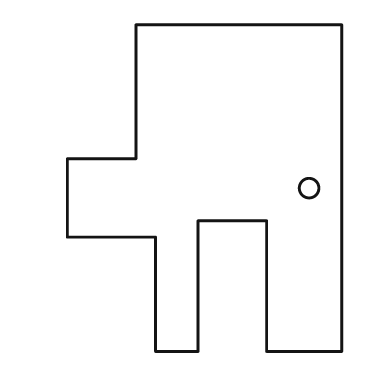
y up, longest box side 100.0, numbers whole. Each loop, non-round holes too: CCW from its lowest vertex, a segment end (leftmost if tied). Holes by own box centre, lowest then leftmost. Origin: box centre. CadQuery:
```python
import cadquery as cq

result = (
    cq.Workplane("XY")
    .moveTo(-15.0, -50.0)
    .lineTo(-2.0, -50.0)
    .lineTo(-2.0, -10.0)
    .lineTo(19.0, -10.0)
    .lineTo(19.0, -50.0)
    .lineTo(42.0, -50.0)
    .lineTo(42.0, 50.0)
    .lineTo(-21.0, 50.0)
    .lineTo(-21.0, 9.0)
    .lineTo(-42.0, 9.0)
    .lineTo(-42.0, -15.0)
    .lineTo(-15.0, -15.0)
    .close()
    .moveTo(32.0, 0.0)
    .circle(3.0)
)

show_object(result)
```